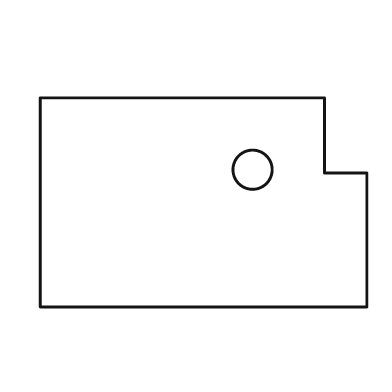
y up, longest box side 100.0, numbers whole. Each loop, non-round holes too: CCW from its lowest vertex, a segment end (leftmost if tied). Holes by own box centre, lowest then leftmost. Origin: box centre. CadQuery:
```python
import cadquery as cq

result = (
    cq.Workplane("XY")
    .moveTo(-50.0, -32.0)
    .lineTo(50.0, -32.0)
    .lineTo(50.0, 9.0)
    .lineTo(37.0, 9.0)
    .lineTo(37.0, 32.0)
    .lineTo(-50.0, 32.0)
    .close()
    .moveTo(15.0, 10.0)
    .circle(6.0)
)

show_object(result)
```